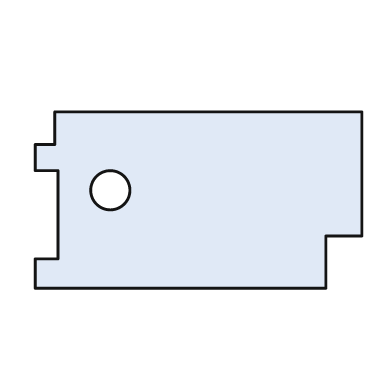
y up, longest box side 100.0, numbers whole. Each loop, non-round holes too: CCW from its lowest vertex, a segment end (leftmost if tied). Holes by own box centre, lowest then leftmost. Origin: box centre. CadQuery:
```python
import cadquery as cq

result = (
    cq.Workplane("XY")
    .moveTo(-50.0, -27.0)
    .lineTo(39.0, -27.0)
    .lineTo(39.0, -11.0)
    .lineTo(50.0, -11.0)
    .lineTo(50.0, 27.0)
    .lineTo(-44.0, 27.0)
    .lineTo(-44.0, 17.0)
    .lineTo(-50.0, 17.0)
    .lineTo(-50.0, 9.0)
    .lineTo(-43.0, 9.0)
    .lineTo(-43.0, -18.0)
    .lineTo(-50.0, -18.0)
    .close()
    .moveTo(-27.0, 3.0)
    .circle(6.0)
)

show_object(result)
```